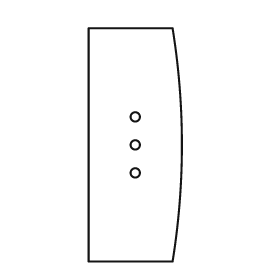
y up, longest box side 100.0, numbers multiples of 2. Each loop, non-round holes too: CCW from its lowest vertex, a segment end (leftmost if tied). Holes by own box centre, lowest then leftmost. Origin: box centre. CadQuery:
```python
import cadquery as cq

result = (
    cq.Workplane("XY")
    .moveTo(-20.0, -50.0)
    .lineTo(16.0, -50.0)
    .threePointArc((20.0, 0.0), (16.0, 50.0))
    .lineTo(-20.0, 50.0)
    .close()
    .moveTo(0.0, -12.0)
    .circle(2.0)
    .moveTo(0.0, 0.0)
    .circle(2.0)
    .moveTo(0.0, 12.0)
    .circle(2.0)
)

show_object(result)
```